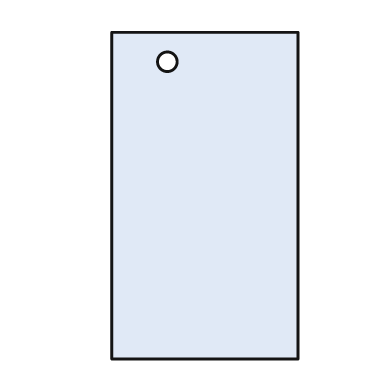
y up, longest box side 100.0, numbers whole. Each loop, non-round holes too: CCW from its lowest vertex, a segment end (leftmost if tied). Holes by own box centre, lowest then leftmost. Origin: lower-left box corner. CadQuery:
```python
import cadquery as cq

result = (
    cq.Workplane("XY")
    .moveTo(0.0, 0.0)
    .lineTo(57.0, 0.0)
    .lineTo(57.0, 100.0)
    .lineTo(0.0, 100.0)
    .close()
    .moveTo(17.0, 91.0)
    .circle(3.0)
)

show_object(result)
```